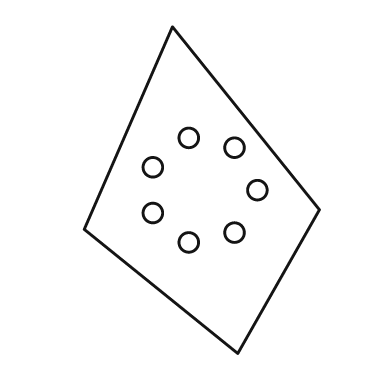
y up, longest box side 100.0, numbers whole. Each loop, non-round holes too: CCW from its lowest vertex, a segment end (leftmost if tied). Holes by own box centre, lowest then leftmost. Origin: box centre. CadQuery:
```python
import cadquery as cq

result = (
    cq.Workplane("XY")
    .moveTo(11.0, -50.0)
    .lineTo(36.0, -6.0)
    .lineTo(-9.0, 50.0)
    .lineTo(-36.0, -12.0)
    .close()
    .moveTo(-4.0, -16.0)
    .circle(3.0)
    .moveTo(10.0, -13.0)
    .circle(3.0)
    .moveTo(-15.0, -7.0)
    .circle(3.0)
    .moveTo(17.0, 0.0)
    .circle(3.0)
    .moveTo(-15.0, 7.0)
    .circle(3.0)
    .moveTo(10.0, 13.0)
    .circle(3.0)
    .moveTo(-4.0, 16.0)
    .circle(3.0)
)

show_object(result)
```